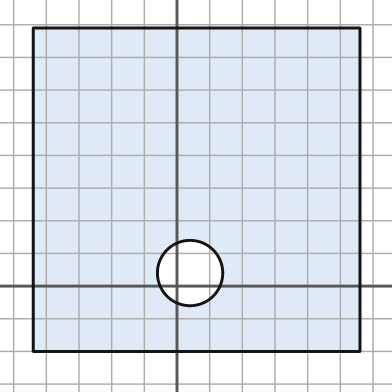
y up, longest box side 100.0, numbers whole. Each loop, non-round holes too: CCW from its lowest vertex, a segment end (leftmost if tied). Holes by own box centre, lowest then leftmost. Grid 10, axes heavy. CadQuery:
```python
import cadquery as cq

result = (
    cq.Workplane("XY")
    .moveTo(-44.0, -20.0)
    .lineTo(56.0, -20.0)
    .lineTo(56.0, 79.0)
    .lineTo(-44.0, 79.0)
    .close()
    .moveTo(4.0, 4.0)
    .circle(10.0)
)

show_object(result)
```